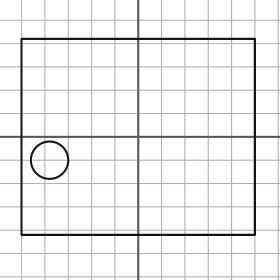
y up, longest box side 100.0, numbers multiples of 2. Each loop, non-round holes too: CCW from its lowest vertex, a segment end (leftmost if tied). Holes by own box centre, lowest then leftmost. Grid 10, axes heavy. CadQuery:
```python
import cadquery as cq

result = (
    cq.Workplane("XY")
    .moveTo(-50.0, -42.0)
    .lineTo(50.0, -42.0)
    .lineTo(50.0, 42.0)
    .lineTo(-50.0, 42.0)
    .close()
    .moveTo(-38.0, -10.0)
    .circle(8.0)
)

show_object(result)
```